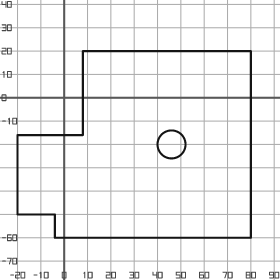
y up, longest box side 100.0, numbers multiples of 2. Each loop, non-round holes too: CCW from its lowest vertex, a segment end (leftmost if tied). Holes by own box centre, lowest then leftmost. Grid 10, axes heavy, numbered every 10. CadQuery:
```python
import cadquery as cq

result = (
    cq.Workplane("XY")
    .moveTo(-4.0, -60.0)
    .lineTo(80.0, -60.0)
    .lineTo(80.0, 20.0)
    .lineTo(8.0, 20.0)
    .lineTo(8.0, -16.0)
    .lineTo(-20.0, -16.0)
    .lineTo(-20.0, -50.0)
    .lineTo(-4.0, -50.0)
    .close()
    .moveTo(46.0, -20.0)
    .circle(6.0)
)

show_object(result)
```